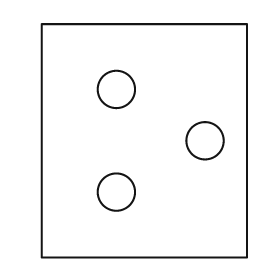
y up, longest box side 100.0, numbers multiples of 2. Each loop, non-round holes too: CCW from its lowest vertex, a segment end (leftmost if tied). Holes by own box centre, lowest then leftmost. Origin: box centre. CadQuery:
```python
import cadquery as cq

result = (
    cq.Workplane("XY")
    .moveTo(-44.0, -50.0)
    .lineTo(44.0, -50.0)
    .lineTo(44.0, 50.0)
    .lineTo(-44.0, 50.0)
    .close()
    .moveTo(-12.0, -22.0)
    .circle(8.0)
    .moveTo(26.0, 0.0)
    .circle(8.0)
    .moveTo(-12.0, 22.0)
    .circle(8.0)
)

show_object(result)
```